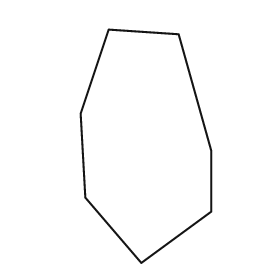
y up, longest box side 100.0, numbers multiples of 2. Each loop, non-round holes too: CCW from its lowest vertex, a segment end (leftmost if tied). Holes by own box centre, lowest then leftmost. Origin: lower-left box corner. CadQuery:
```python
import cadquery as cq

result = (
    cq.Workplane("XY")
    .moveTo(26.0, 0.0)
    .lineTo(56.0, 22.0)
    .lineTo(56.0, 48.0)
    .lineTo(42.0, 98.0)
    .lineTo(12.0, 100.0)
    .lineTo(0.0, 64.0)
    .lineTo(2.0, 28.0)
    .close()
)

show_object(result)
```